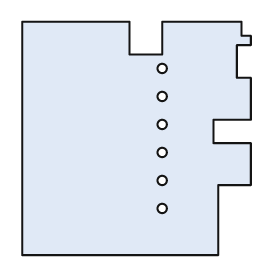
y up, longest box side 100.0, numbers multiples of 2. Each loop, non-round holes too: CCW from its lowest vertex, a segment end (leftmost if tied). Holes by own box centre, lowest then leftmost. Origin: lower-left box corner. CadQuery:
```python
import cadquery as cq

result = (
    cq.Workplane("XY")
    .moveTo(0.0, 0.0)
    .lineTo(84.0, 0.0)
    .lineTo(84.0, 30.0)
    .lineTo(98.0, 30.0)
    .lineTo(98.0, 48.0)
    .lineTo(82.0, 48.0)
    .lineTo(82.0, 58.0)
    .lineTo(98.0, 58.0)
    .lineTo(98.0, 76.0)
    .lineTo(92.0, 76.0)
    .lineTo(92.0, 90.0)
    .lineTo(98.0, 90.0)
    .lineTo(98.0, 94.0)
    .lineTo(94.0, 94.0)
    .lineTo(94.0, 100.0)
    .lineTo(60.0, 100.0)
    .lineTo(60.0, 86.0)
    .lineTo(46.0, 86.0)
    .lineTo(46.0, 100.0)
    .lineTo(0.0, 100.0)
    .close()
    .moveTo(60.0, 20.0)
    .circle(2.0)
    .moveTo(60.0, 32.0)
    .circle(2.0)
    .moveTo(60.0, 44.0)
    .circle(2.0)
    .moveTo(60.0, 56.0)
    .circle(2.0)
    .moveTo(60.0, 68.0)
    .circle(2.0)
    .moveTo(60.0, 80.0)
    .circle(2.0)
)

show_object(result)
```